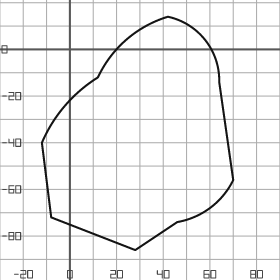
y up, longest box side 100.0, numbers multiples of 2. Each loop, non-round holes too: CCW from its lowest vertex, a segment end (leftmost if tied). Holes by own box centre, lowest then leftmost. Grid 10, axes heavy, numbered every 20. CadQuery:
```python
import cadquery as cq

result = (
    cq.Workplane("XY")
    .moveTo(28.0, -86.0)
    .lineTo(46.0, -74.0)
    .threePointArc((60.0, -68.0), (70.0, -56.0))
    .lineTo(64.0, -14.0)
    .threePointArc((58.0, 4.0), (42.0, 14.0))
    .threePointArc((24.0, 4.0), (12.0, -12.0))
    .threePointArc((-2.0, -24.0), (-12.0, -40.0))
    .lineTo(-8.0, -72.0)
    .close()
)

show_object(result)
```